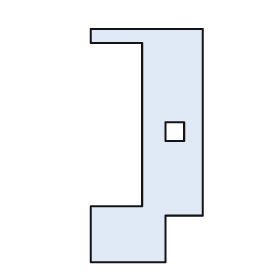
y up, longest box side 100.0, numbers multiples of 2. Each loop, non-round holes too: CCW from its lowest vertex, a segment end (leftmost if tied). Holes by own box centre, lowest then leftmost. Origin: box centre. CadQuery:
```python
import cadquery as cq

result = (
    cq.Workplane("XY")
    .moveTo(-24.0, -50.0)
    .lineTo(8.0, -50.0)
    .lineTo(8.0, -30.0)
    .lineTo(24.0, -30.0)
    .lineTo(24.0, 50.0)
    .lineTo(-24.0, 50.0)
    .lineTo(-24.0, 44.0)
    .lineTo(-2.0, 44.0)
    .lineTo(-2.0, -26.0)
    .lineTo(-24.0, -26.0)
    .close()
    .moveTo(8.0, 2.0)
    .lineTo(16.0, 2.0)
    .lineTo(16.0, 10.0)
    .lineTo(8.0, 10.0)
    .close()
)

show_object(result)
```